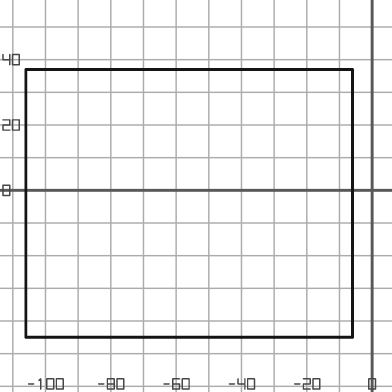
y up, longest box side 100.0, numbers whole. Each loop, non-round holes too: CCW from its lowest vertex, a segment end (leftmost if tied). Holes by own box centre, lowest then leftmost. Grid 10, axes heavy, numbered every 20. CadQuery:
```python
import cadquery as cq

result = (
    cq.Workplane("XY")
    .moveTo(-106.0, -45.0)
    .lineTo(-6.0, -45.0)
    .lineTo(-6.0, 37.0)
    .lineTo(-106.0, 37.0)
    .close()
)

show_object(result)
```